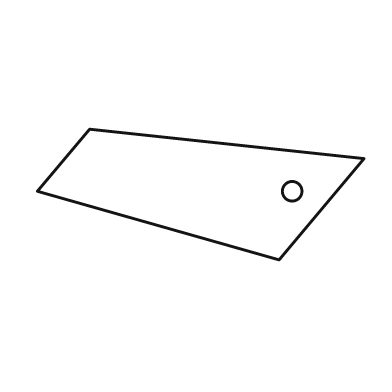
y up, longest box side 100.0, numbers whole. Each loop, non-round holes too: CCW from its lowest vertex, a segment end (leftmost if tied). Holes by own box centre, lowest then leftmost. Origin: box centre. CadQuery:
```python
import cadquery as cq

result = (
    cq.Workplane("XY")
    .moveTo(24.0, -20.0)
    .lineTo(50.0, 11.0)
    .lineTo(-34.0, 20.0)
    .lineTo(-50.0, 1.0)
    .close()
    .moveTo(28.0, 1.0)
    .circle(3.0)
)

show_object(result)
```